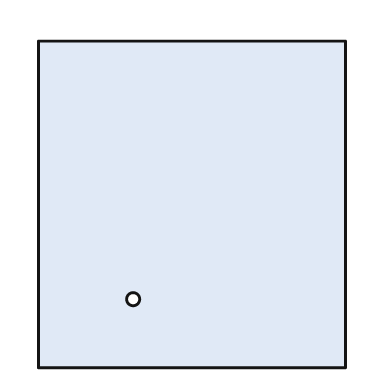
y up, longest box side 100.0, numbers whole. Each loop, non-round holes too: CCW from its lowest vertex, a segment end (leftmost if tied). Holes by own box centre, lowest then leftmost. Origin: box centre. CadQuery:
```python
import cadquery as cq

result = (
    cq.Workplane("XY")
    .moveTo(-47.0, -50.0)
    .lineTo(47.0, -50.0)
    .lineTo(47.0, 50.0)
    .lineTo(-47.0, 50.0)
    .close()
    .moveTo(-18.0, -29.0)
    .circle(2.0)
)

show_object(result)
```